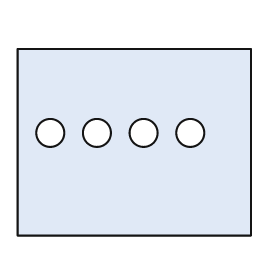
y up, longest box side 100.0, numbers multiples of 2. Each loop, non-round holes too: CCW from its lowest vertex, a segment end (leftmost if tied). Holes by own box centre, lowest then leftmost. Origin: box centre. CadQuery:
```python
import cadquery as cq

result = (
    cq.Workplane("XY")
    .moveTo(-50.0, -40.0)
    .lineTo(50.0, -40.0)
    .lineTo(50.0, 40.0)
    .lineTo(-50.0, 40.0)
    .close()
    .moveTo(-36.0, 4.0)
    .circle(6.0)
    .moveTo(-16.0, 4.0)
    .circle(6.0)
    .moveTo(4.0, 4.0)
    .circle(6.0)
    .moveTo(24.0, 4.0)
    .circle(6.0)
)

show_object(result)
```